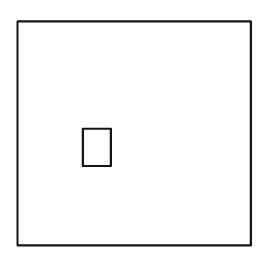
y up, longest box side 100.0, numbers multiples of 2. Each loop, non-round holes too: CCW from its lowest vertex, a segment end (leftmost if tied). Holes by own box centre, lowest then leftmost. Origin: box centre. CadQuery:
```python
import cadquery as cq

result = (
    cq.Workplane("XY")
    .moveTo(-50.0, -48.0)
    .lineTo(50.0, -48.0)
    .lineTo(50.0, 48.0)
    .lineTo(-50.0, 48.0)
    .close()
    .moveTo(-22.0, -14.0)
    .lineTo(-10.0, -14.0)
    .lineTo(-10.0, 2.0)
    .lineTo(-22.0, 2.0)
    .close()
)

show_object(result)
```